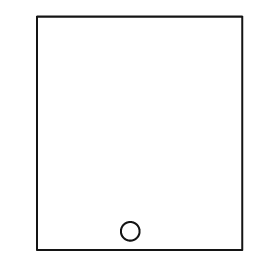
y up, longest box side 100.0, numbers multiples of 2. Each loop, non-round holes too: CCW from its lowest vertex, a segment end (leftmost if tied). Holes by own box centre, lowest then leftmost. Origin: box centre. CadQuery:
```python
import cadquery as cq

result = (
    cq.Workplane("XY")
    .moveTo(-44.0, -50.0)
    .lineTo(44.0, -50.0)
    .lineTo(44.0, 50.0)
    .lineTo(-44.0, 50.0)
    .close()
    .moveTo(-4.0, -42.0)
    .circle(4.0)
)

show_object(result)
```